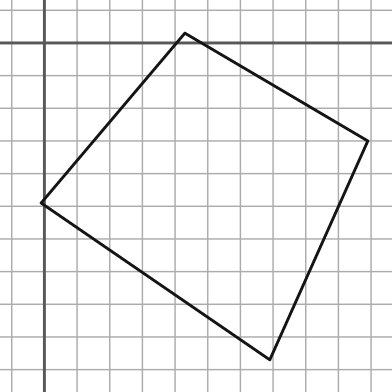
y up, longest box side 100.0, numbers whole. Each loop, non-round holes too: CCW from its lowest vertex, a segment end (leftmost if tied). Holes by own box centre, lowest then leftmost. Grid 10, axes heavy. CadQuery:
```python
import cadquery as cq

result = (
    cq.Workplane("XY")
    .moveTo(69.0, -97.0)
    .lineTo(99.0, -30.0)
    .lineTo(43.0, 3.0)
    .lineTo(-1.0, -49.0)
    .close()
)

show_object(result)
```